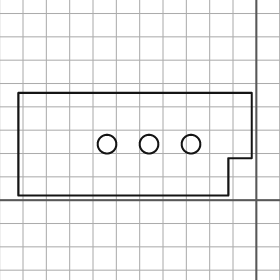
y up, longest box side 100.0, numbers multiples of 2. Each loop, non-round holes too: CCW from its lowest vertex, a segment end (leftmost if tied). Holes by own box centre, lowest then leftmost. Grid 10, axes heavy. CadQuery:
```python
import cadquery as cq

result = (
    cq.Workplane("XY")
    .moveTo(-102.0, 2.0)
    .lineTo(-12.0, 2.0)
    .lineTo(-12.0, 18.0)
    .lineTo(-2.0, 18.0)
    .lineTo(-2.0, 46.0)
    .lineTo(-102.0, 46.0)
    .close()
    .moveTo(-64.0, 24.0)
    .circle(4.0)
    .moveTo(-46.0, 24.0)
    .circle(4.0)
    .moveTo(-28.0, 24.0)
    .circle(4.0)
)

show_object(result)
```